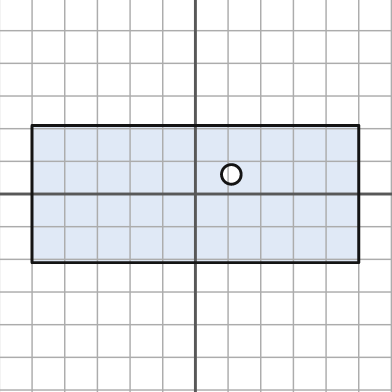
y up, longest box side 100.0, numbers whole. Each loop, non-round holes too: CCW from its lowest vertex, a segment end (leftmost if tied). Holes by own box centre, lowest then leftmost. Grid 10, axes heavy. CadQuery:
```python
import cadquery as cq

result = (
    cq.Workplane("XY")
    .moveTo(-50.0, -21.0)
    .lineTo(50.0, -21.0)
    .lineTo(50.0, 21.0)
    .lineTo(-50.0, 21.0)
    .close()
    .moveTo(11.0, 6.0)
    .circle(3.0)
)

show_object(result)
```